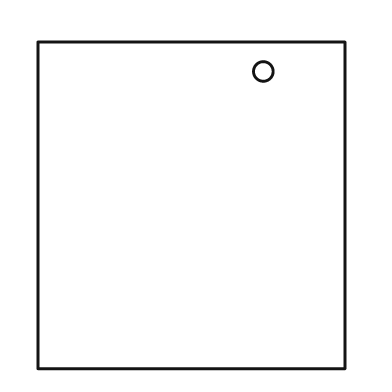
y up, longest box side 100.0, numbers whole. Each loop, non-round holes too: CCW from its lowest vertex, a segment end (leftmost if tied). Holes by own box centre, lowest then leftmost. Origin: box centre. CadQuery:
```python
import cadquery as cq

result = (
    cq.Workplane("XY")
    .moveTo(-47.0, -50.0)
    .lineTo(47.0, -50.0)
    .lineTo(47.0, 50.0)
    .lineTo(-47.0, 50.0)
    .close()
    .moveTo(22.0, 41.0)
    .circle(3.0)
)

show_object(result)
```